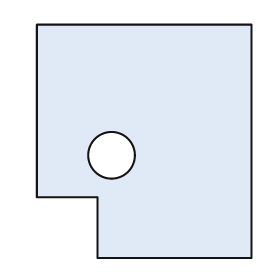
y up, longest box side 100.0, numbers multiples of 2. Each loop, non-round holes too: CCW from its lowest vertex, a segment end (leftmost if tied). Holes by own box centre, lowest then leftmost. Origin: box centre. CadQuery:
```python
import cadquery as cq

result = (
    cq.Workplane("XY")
    .moveTo(-20.0, -50.0)
    .lineTo(46.0, -50.0)
    .lineTo(46.0, 50.0)
    .lineTo(-46.0, 50.0)
    .lineTo(-46.0, -24.0)
    .lineTo(-20.0, -24.0)
    .close()
    .moveTo(-14.0, -6.0)
    .circle(10.0)
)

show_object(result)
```